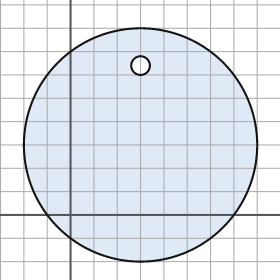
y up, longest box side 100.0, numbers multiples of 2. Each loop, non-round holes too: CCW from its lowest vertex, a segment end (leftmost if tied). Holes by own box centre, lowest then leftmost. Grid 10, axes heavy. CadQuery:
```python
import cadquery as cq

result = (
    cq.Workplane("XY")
    .moveTo(30.0, 30.0)
    .circle(50.0)
    .moveTo(30.0, 64.0)
    .circle(4.0)
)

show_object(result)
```